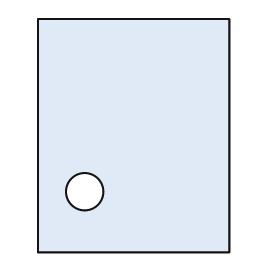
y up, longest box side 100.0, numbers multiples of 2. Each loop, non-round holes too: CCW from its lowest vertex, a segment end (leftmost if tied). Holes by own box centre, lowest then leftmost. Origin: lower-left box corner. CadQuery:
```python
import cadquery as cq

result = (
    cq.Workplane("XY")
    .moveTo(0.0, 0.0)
    .lineTo(82.0, 0.0)
    .lineTo(82.0, 100.0)
    .lineTo(0.0, 100.0)
    .close()
    .moveTo(20.0, 26.0)
    .circle(8.0)
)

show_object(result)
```